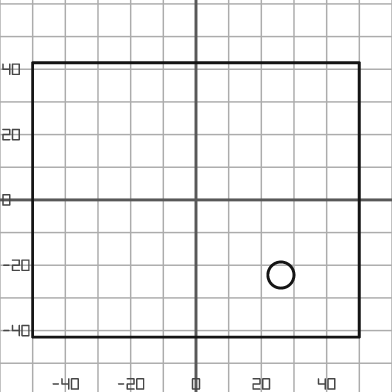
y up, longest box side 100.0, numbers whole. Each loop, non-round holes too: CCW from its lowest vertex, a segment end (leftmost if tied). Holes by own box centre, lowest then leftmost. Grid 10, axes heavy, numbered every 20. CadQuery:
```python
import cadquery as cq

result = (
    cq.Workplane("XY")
    .moveTo(-50.0, -42.0)
    .lineTo(50.0, -42.0)
    .lineTo(50.0, 42.0)
    .lineTo(-50.0, 42.0)
    .close()
    .moveTo(26.0, -23.0)
    .circle(4.0)
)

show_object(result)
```